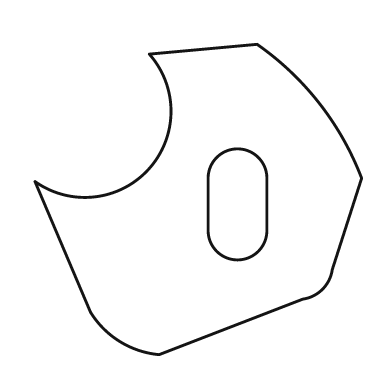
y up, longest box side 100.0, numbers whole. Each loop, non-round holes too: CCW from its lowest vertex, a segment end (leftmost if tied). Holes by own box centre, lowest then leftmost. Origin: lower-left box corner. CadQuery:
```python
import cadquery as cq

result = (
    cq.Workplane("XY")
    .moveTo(38.0, 0.0)
    .lineTo(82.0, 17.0)
    .threePointArc((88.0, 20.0), (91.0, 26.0))
    .lineTo(100.0, 54.0)
    .threePointArc((87.0, 77.0), (68.0, 95.0))
    .lineTo(35.0, 92.0)
    .threePointArc((35.0, 57.0), (0.0, 53.0))
    .lineTo(17.0, 13.0)
    .threePointArc((26.0, 4.0), (38.0, 0.0))
    .close()
    .moveTo(53.0, 38.0)
    .threePointArc((62.0, 29.0), (71.0, 38.0))
    .lineTo(71.0, 54.0)
    .threePointArc((62.0, 63.0), (53.0, 54.0))
    .close()
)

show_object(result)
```